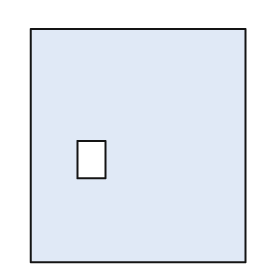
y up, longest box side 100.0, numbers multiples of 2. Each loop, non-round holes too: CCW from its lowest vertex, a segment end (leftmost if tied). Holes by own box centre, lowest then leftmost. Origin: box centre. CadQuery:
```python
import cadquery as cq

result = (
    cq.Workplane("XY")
    .moveTo(-46.0, -50.0)
    .lineTo(46.0, -50.0)
    .lineTo(46.0, 50.0)
    .lineTo(-46.0, 50.0)
    .close()
    .moveTo(-26.0, -14.0)
    .lineTo(-14.0, -14.0)
    .lineTo(-14.0, 2.0)
    .lineTo(-26.0, 2.0)
    .close()
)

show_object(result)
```